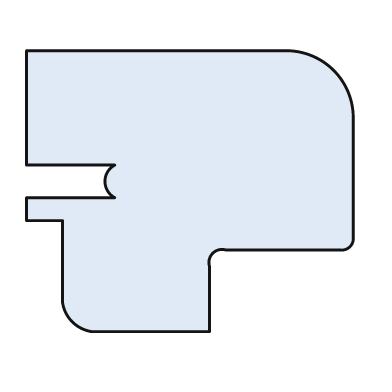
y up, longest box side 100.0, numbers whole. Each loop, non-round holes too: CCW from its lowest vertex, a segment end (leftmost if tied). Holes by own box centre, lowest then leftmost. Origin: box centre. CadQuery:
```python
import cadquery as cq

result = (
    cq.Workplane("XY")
    .moveTo(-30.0, -43.0)
    .lineTo(6.0, -43.0)
    .lineTo(6.0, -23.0)
    .threePointArc((7.0, -19.0), (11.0, -18.0))
    .lineTo(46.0, -18.0)
    .threePointArc((49.0, -17.0), (50.0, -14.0))
    .lineTo(50.0, 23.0)
    .threePointArc((44.0, 37.0), (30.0, 43.0))
    .lineTo(-50.0, 43.0)
    .lineTo(-50.0, 8.0)
    .lineTo(-23.0, 8.0)
    .threePointArc((-26.0, 3.0), (-23.0, -2.0))
    .lineTo(-50.0, -2.0)
    .lineTo(-50.0, -9.0)
    .lineTo(-39.0, -9.0)
    .lineTo(-39.0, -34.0)
    .threePointArc((-36.0, -40.0), (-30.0, -43.0))
    .close()
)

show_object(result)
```